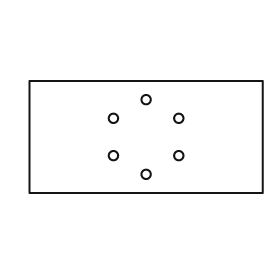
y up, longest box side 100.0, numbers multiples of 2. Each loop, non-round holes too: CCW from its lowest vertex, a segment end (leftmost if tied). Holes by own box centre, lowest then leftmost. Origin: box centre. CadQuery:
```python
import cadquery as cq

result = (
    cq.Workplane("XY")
    .moveTo(-50.0, -24.0)
    .lineTo(50.0, -24.0)
    .lineTo(50.0, 24.0)
    .lineTo(-50.0, 24.0)
    .close()
    .moveTo(0.0, -16.0)
    .circle(2.0)
    .moveTo(-14.0, -8.0)
    .circle(2.0)
    .moveTo(14.0, -8.0)
    .circle(2.0)
    .moveTo(-14.0, 8.0)
    .circle(2.0)
    .moveTo(14.0, 8.0)
    .circle(2.0)
    .moveTo(0.0, 16.0)
    .circle(2.0)
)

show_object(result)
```